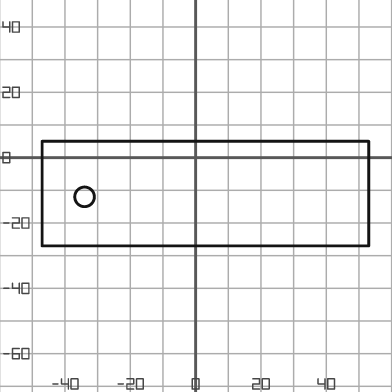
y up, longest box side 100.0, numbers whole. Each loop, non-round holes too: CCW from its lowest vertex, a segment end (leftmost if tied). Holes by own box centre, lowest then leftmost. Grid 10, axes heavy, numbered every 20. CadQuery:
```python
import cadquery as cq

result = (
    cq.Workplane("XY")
    .moveTo(-47.0, -27.0)
    .lineTo(53.0, -27.0)
    .lineTo(53.0, 5.0)
    .lineTo(-47.0, 5.0)
    .close()
    .moveTo(-34.0, -12.0)
    .circle(3.0)
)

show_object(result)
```